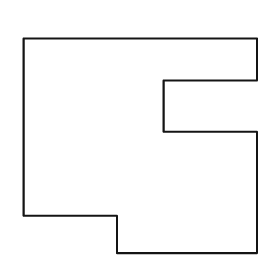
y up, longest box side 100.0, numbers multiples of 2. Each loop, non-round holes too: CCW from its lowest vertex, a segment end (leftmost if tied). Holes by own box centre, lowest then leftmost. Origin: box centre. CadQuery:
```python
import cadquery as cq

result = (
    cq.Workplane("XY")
    .moveTo(-10.0, -46.0)
    .lineTo(50.0, -46.0)
    .lineTo(50.0, 6.0)
    .lineTo(10.0, 6.0)
    .lineTo(10.0, 28.0)
    .lineTo(50.0, 28.0)
    .lineTo(50.0, 46.0)
    .lineTo(-50.0, 46.0)
    .lineTo(-50.0, -30.0)
    .lineTo(-10.0, -30.0)
    .close()
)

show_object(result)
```